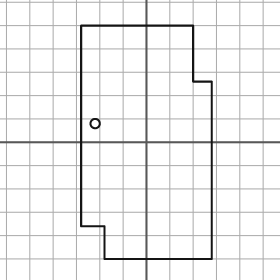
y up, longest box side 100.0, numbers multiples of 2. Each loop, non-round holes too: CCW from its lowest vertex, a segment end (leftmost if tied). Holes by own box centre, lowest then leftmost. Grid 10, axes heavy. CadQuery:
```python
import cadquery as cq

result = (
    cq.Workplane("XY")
    .moveTo(-18.0, -50.0)
    .lineTo(28.0, -50.0)
    .lineTo(28.0, 26.0)
    .lineTo(20.0, 26.0)
    .lineTo(20.0, 50.0)
    .lineTo(-28.0, 50.0)
    .lineTo(-28.0, -36.0)
    .lineTo(-18.0, -36.0)
    .close()
    .moveTo(-22.0, 8.0)
    .circle(2.0)
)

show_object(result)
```